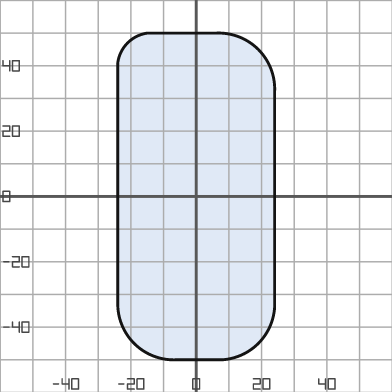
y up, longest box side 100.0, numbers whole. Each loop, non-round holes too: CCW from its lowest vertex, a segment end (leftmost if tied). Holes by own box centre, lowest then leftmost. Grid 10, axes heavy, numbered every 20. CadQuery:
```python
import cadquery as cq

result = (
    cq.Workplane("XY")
    .moveTo(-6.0, -50.0)
    .lineTo(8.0, -50.0)
    .threePointArc((19.0, -45.0), (24.0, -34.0))
    .lineTo(24.0, 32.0)
    .threePointArc((19.0, 45.0), (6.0, 50.0))
    .lineTo(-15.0, 50.0)
    .threePointArc((-21.0, 47.0), (-24.0, 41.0))
    .lineTo(-24.0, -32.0)
    .threePointArc((-19.0, -45.0), (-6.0, -50.0))
    .close()
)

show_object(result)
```